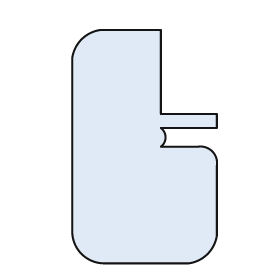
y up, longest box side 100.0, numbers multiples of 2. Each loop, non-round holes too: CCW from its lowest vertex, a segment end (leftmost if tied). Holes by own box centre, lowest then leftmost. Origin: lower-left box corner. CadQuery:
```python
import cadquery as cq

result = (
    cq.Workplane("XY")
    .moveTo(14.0, 0.0)
    .lineTo(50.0, 0.0)
    .threePointArc((58.0, 4.0), (62.0, 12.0))
    .lineTo(62.0, 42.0)
    .threePointArc((60.0, 48.0), (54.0, 50.0))
    .lineTo(38.0, 50.0)
    .threePointArc((40.0, 54.0), (38.0, 58.0))
    .lineTo(62.0, 58.0)
    .lineTo(62.0, 64.0)
    .lineTo(38.0, 64.0)
    .lineTo(38.0, 100.0)
    .lineTo(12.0, 100.0)
    .threePointArc((4.0, 96.0), (0.0, 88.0))
    .lineTo(0.0, 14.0)
    .threePointArc((4.0, 4.0), (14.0, 0.0))
    .close()
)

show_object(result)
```